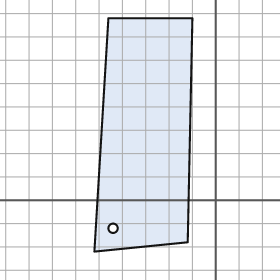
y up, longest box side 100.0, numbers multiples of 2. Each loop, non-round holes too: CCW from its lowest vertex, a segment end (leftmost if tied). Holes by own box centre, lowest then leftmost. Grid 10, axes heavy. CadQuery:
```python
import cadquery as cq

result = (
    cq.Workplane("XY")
    .moveTo(-52.0, -22.0)
    .lineTo(-12.0, -18.0)
    .lineTo(-10.0, 78.0)
    .lineTo(-46.0, 78.0)
    .close()
    .moveTo(-44.0, -12.0)
    .circle(2.0)
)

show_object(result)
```